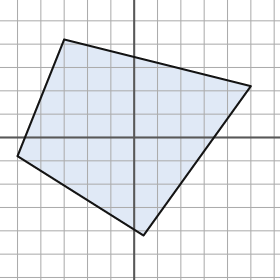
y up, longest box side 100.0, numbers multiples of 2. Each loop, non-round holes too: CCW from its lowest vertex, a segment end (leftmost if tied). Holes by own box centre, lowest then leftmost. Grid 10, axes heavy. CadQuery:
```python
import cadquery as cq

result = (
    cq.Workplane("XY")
    .moveTo(4.0, -42.0)
    .lineTo(50.0, 22.0)
    .lineTo(-30.0, 42.0)
    .lineTo(-50.0, -8.0)
    .close()
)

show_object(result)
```